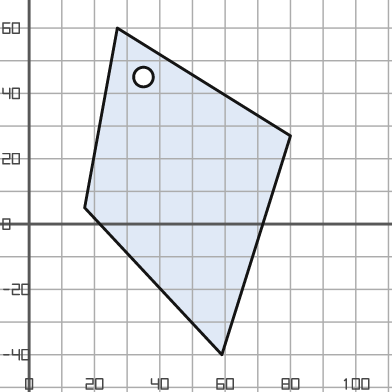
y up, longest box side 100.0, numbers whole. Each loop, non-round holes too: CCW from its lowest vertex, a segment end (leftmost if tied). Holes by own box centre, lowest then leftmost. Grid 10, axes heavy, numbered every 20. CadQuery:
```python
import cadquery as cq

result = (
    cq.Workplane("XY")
    .moveTo(59.0, -40.0)
    .lineTo(80.0, 27.0)
    .lineTo(27.0, 60.0)
    .lineTo(17.0, 5.0)
    .close()
    .moveTo(35.0, 45.0)
    .circle(3.0)
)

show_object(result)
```